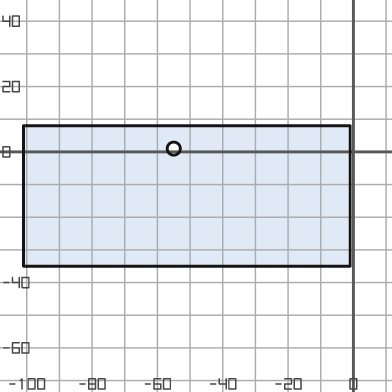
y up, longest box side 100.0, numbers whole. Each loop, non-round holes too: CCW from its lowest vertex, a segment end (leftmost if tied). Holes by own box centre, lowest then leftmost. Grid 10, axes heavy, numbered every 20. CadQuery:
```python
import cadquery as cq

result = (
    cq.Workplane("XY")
    .moveTo(-101.0, -35.0)
    .lineTo(-1.0, -35.0)
    .lineTo(-1.0, 8.0)
    .lineTo(-101.0, 8.0)
    .close()
    .moveTo(-55.0, 1.0)
    .circle(2.0)
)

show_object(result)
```